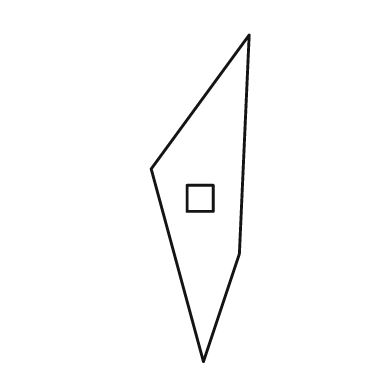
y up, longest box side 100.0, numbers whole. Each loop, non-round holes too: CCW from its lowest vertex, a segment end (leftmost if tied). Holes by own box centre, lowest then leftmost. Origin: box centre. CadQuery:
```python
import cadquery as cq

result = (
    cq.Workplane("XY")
    .moveTo(1.0, -50.0)
    .lineTo(12.0, -17.0)
    .lineTo(15.0, 50.0)
    .lineTo(-15.0, 9.0)
    .close()
    .moveTo(-4.0, -4.0)
    .lineTo(4.0, -4.0)
    .lineTo(4.0, 4.0)
    .lineTo(-4.0, 4.0)
    .close()
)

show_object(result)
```